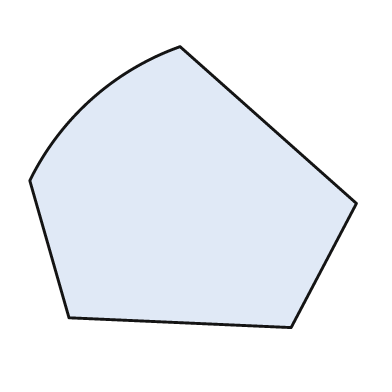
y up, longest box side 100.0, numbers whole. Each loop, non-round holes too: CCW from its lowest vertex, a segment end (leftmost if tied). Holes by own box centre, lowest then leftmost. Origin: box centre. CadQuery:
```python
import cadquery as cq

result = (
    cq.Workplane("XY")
    .moveTo(30.0, -43.0)
    .lineTo(50.0, -5.0)
    .lineTo(-4.0, 43.0)
    .threePointArc((-31.0, 27.0), (-50.0, 2.0))
    .lineTo(-38.0, -40.0)
    .close()
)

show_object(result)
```